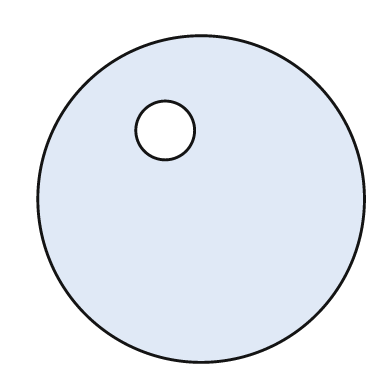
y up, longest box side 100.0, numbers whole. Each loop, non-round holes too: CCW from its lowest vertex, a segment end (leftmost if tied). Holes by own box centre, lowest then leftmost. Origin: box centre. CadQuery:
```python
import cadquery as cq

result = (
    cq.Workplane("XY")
    .moveTo(0.0, 0.0)
    .circle(50.0)
    .moveTo(-11.0, 21.0)
    .circle(9.0)
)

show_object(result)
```